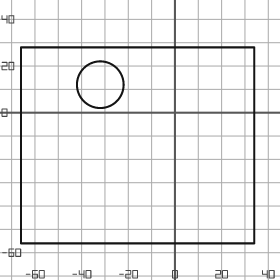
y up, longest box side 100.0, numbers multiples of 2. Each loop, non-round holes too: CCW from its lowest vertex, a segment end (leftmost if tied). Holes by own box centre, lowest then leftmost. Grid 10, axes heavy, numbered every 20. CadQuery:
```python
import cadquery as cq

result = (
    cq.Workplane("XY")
    .moveTo(-66.0, -56.0)
    .lineTo(34.0, -56.0)
    .lineTo(34.0, 28.0)
    .lineTo(-66.0, 28.0)
    .close()
    .moveTo(-32.0, 12.0)
    .circle(10.0)
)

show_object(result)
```